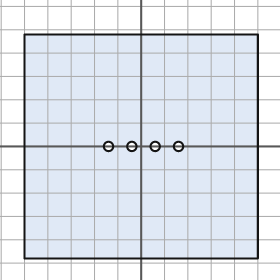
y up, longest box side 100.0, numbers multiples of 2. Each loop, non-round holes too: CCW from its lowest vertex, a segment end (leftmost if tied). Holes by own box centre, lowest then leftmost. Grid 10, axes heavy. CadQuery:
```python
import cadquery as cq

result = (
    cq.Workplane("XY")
    .moveTo(-50.0, -48.0)
    .lineTo(50.0, -48.0)
    .lineTo(50.0, 48.0)
    .lineTo(-50.0, 48.0)
    .close()
    .moveTo(-14.0, 0.0)
    .circle(2.0)
    .moveTo(-4.0, 0.0)
    .circle(2.0)
    .moveTo(6.0, 0.0)
    .circle(2.0)
    .moveTo(16.0, 0.0)
    .circle(2.0)
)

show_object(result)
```